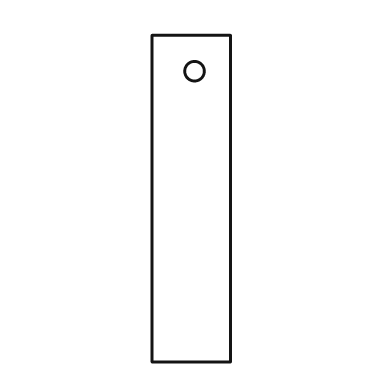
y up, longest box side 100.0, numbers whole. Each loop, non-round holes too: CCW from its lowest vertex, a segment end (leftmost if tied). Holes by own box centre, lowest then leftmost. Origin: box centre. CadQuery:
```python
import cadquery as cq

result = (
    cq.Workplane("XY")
    .moveTo(-12.0, -50.0)
    .lineTo(12.0, -50.0)
    .lineTo(12.0, 50.0)
    .lineTo(-12.0, 50.0)
    .close()
    .moveTo(1.0, 39.0)
    .circle(3.0)
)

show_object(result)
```